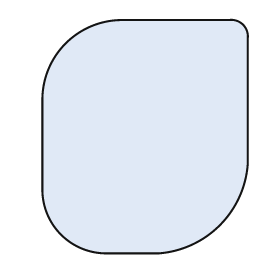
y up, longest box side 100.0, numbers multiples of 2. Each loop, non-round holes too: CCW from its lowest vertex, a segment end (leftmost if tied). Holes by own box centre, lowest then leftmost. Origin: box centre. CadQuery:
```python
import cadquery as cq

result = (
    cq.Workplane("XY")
    .moveTo(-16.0, -50.0)
    .lineTo(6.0, -50.0)
    .threePointArc((32.0, -38.0), (44.0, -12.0))
    .lineTo(44.0, 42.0)
    .threePointArc((42.0, 48.0), (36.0, 50.0))
    .lineTo(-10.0, 50.0)
    .threePointArc((-34.0, 40.0), (-44.0, 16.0))
    .lineTo(-44.0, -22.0)
    .threePointArc((-36.0, -42.0), (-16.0, -50.0))
    .close()
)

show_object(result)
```